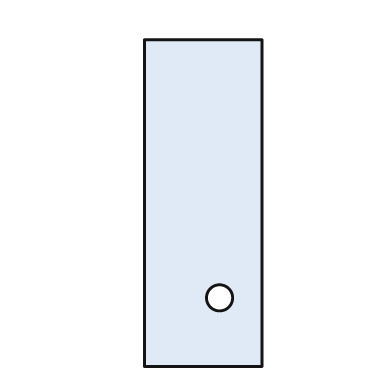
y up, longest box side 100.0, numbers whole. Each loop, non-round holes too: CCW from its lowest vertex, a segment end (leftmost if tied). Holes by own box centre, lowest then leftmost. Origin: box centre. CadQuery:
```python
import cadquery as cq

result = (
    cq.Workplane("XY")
    .moveTo(-18.0, -50.0)
    .lineTo(18.0, -50.0)
    .lineTo(18.0, 50.0)
    .lineTo(-18.0, 50.0)
    .close()
    .moveTo(5.0, -29.0)
    .circle(4.0)
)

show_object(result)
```